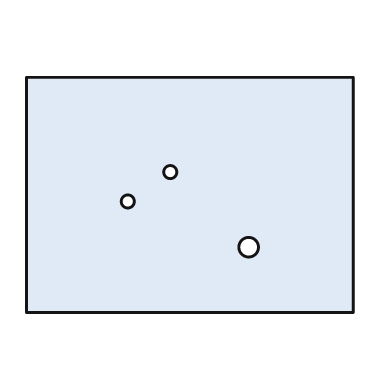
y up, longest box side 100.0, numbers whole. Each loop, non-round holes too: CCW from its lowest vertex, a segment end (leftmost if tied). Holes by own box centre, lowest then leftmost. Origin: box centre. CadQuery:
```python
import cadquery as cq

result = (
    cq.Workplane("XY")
    .moveTo(-50.0, -36.0)
    .lineTo(50.0, -36.0)
    .lineTo(50.0, 36.0)
    .lineTo(-50.0, 36.0)
    .close()
    .moveTo(18.0, -16.0)
    .circle(3.0)
    .moveTo(-19.0, -2.0)
    .circle(2.0)
    .moveTo(-6.0, 7.0)
    .circle(2.0)
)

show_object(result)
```